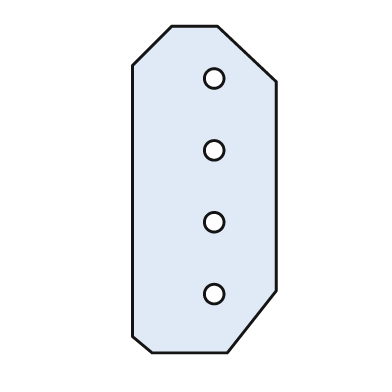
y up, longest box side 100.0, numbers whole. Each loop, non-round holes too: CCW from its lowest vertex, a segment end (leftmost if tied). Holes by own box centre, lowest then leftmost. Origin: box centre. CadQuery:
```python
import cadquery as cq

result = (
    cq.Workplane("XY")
    .moveTo(-16.0, -50.0)
    .lineTo(7.0, -50.0)
    .lineTo(22.0, -31.0)
    .lineTo(22.0, 33.0)
    .lineTo(4.0, 50.0)
    .lineTo(-10.0, 50.0)
    .lineTo(-22.0, 38.0)
    .lineTo(-22.0, -45.0)
    .close()
    .moveTo(3.0, -32.0)
    .circle(3.0)
    .moveTo(3.0, -10.0)
    .circle(3.0)
    .moveTo(3.0, 12.0)
    .circle(3.0)
    .moveTo(3.0, 34.0)
    .circle(3.0)
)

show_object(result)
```